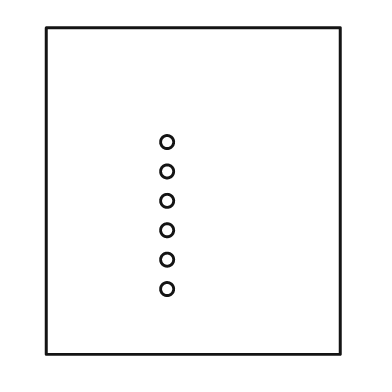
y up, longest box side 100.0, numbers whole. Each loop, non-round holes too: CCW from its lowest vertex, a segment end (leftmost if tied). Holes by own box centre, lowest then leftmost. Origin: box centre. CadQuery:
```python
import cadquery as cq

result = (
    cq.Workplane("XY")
    .moveTo(-45.0, -50.0)
    .lineTo(45.0, -50.0)
    .lineTo(45.0, 50.0)
    .lineTo(-45.0, 50.0)
    .close()
    .moveTo(-8.0, -30.0)
    .circle(2.0)
    .moveTo(-8.0, -21.0)
    .circle(2.0)
    .moveTo(-8.0, -12.0)
    .circle(2.0)
    .moveTo(-8.0, -3.0)
    .circle(2.0)
    .moveTo(-8.0, 6.0)
    .circle(2.0)
    .moveTo(-8.0, 15.0)
    .circle(2.0)
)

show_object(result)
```